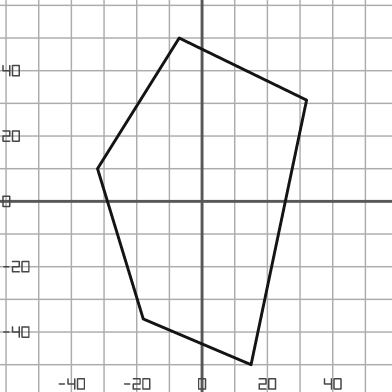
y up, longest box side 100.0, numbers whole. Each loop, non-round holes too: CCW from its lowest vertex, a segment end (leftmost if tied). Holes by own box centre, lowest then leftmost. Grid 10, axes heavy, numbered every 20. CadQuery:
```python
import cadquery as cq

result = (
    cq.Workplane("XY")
    .moveTo(15.0, -50.0)
    .lineTo(32.0, 31.0)
    .lineTo(-7.0, 50.0)
    .lineTo(-32.0, 10.0)
    .lineTo(-18.0, -36.0)
    .close()
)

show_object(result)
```